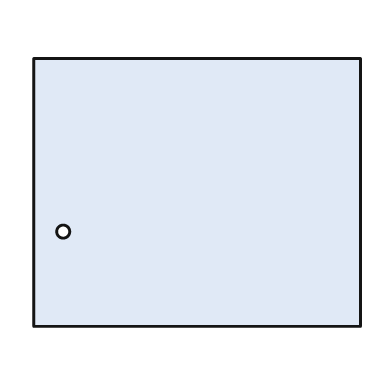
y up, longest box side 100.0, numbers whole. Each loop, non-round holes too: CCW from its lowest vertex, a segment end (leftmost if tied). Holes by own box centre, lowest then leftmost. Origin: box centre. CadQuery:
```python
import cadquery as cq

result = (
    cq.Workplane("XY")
    .moveTo(-50.0, -41.0)
    .lineTo(50.0, -41.0)
    .lineTo(50.0, 41.0)
    .lineTo(-50.0, 41.0)
    .close()
    .moveTo(-41.0, -12.0)
    .circle(2.0)
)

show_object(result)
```